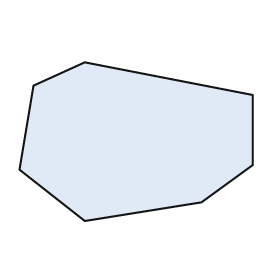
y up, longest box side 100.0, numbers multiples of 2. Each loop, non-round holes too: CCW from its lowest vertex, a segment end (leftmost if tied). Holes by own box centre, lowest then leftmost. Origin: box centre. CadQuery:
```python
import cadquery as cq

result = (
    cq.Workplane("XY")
    .moveTo(-22.0, -34.0)
    .lineTo(28.0, -26.0)
    .lineTo(50.0, -10.0)
    .lineTo(50.0, 20.0)
    .lineTo(-22.0, 34.0)
    .lineTo(-44.0, 24.0)
    .lineTo(-50.0, -12.0)
    .close()
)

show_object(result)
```